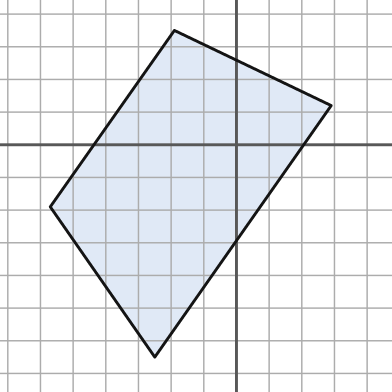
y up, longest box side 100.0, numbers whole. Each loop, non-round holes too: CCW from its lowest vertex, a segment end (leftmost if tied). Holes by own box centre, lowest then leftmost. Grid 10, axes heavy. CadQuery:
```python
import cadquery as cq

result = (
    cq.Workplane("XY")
    .moveTo(-25.0, -65.0)
    .lineTo(29.0, 12.0)
    .lineTo(-19.0, 35.0)
    .lineTo(-57.0, -19.0)
    .close()
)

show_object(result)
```